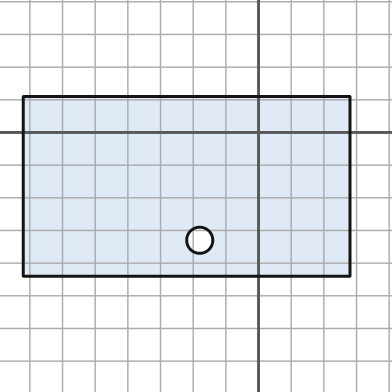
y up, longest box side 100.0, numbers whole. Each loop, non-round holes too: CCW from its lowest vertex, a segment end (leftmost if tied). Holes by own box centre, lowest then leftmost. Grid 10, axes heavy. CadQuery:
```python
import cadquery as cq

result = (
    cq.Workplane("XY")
    .moveTo(-72.0, -44.0)
    .lineTo(28.0, -44.0)
    .lineTo(28.0, 11.0)
    .lineTo(-72.0, 11.0)
    .close()
    .moveTo(-18.0, -33.0)
    .circle(4.0)
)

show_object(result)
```